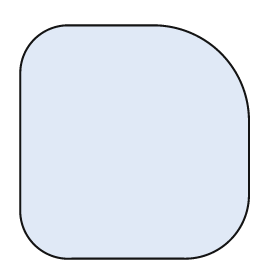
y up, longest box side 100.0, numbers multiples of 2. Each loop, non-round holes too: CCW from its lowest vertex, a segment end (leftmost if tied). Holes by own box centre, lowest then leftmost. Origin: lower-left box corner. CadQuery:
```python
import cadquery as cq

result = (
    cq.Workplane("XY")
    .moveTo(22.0, 0.0)
    .lineTo(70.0, 0.0)
    .threePointArc((90.0, 8.0), (98.0, 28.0))
    .lineTo(98.0, 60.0)
    .threePointArc((86.0, 88.0), (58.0, 100.0))
    .lineTo(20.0, 100.0)
    .threePointArc((6.0, 94.0), (0.0, 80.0))
    .lineTo(0.0, 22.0)
    .threePointArc((6.0, 6.0), (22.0, 0.0))
    .close()
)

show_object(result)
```